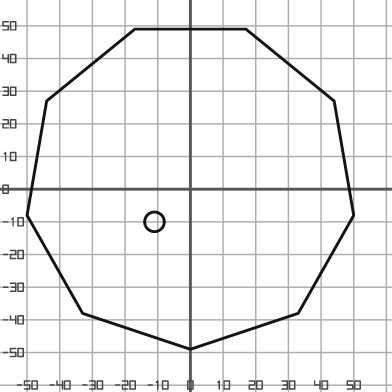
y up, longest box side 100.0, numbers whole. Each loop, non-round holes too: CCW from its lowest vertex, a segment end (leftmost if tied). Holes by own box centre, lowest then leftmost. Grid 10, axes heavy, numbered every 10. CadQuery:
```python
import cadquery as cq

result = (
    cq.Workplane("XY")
    .moveTo(0.0, -49.0)
    .lineTo(33.0, -38.0)
    .lineTo(50.0, -8.0)
    .lineTo(44.0, 27.0)
    .lineTo(17.0, 49.0)
    .lineTo(-17.0, 49.0)
    .lineTo(-44.0, 27.0)
    .lineTo(-50.0, -8.0)
    .lineTo(-33.0, -38.0)
    .close()
    .moveTo(-11.0, -10.0)
    .circle(3.0)
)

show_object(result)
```